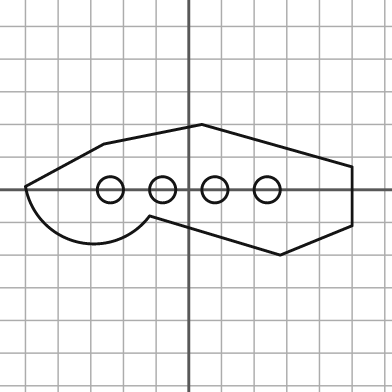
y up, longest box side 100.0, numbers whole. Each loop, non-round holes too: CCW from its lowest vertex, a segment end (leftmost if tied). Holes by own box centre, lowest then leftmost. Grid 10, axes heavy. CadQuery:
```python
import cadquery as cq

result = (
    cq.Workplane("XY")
    .moveTo(28.0, -20.0)
    .lineTo(50.0, -11.0)
    .lineTo(50.0, 7.0)
    .lineTo(4.0, 20.0)
    .lineTo(-26.0, 14.0)
    .lineTo(-50.0, 1.0)
    .threePointArc((-34.0, -16.0), (-12.0, -8.0))
    .close()
    .moveTo(-24.0, 0.0)
    .circle(4.0)
    .moveTo(-8.0, 0.0)
    .circle(4.0)
    .moveTo(8.0, 0.0)
    .circle(4.0)
    .moveTo(24.0, 0.0)
    .circle(4.0)
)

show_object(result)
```